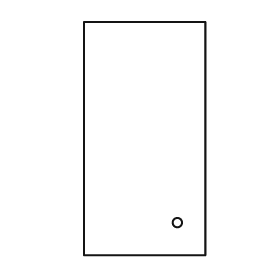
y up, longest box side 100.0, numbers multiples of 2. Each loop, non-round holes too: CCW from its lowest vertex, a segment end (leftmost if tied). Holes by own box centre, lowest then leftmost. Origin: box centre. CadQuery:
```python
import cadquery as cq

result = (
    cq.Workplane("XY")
    .moveTo(-26.0, -50.0)
    .lineTo(26.0, -50.0)
    .lineTo(26.0, 50.0)
    .lineTo(-26.0, 50.0)
    .close()
    .moveTo(14.0, -36.0)
    .circle(2.0)
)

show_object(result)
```